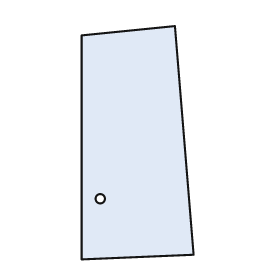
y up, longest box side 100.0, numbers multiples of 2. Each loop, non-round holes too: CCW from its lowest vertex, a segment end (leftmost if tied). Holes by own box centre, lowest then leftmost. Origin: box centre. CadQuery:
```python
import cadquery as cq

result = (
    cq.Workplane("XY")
    .moveTo(-24.0, -50.0)
    .lineTo(24.0, -48.0)
    .lineTo(16.0, 50.0)
    .lineTo(-24.0, 46.0)
    .close()
    .moveTo(-16.0, -24.0)
    .circle(2.0)
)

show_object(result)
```